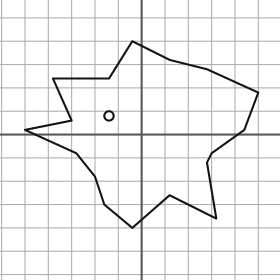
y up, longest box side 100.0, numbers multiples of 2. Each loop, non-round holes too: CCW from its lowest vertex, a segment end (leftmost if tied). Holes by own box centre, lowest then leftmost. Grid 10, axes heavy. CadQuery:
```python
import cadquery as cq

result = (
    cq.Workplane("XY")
    .moveTo(-4.0, -40.0)
    .lineTo(12.0, -26.0)
    .lineTo(32.0, -36.0)
    .lineTo(28.0, -12.0)
    .lineTo(30.0, -8.0)
    .lineTo(44.0, 2.0)
    .lineTo(50.0, 18.0)
    .lineTo(28.0, 28.0)
    .lineTo(12.0, 32.0)
    .lineTo(-4.0, 40.0)
    .lineTo(-14.0, 24.0)
    .lineTo(-38.0, 24.0)
    .lineTo(-30.0, 6.0)
    .lineTo(-50.0, 2.0)
    .lineTo(-28.0, -8.0)
    .lineTo(-20.0, -18.0)
    .lineTo(-16.0, -30.0)
    .close()
    .moveTo(-14.0, 8.0)
    .circle(2.0)
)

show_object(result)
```